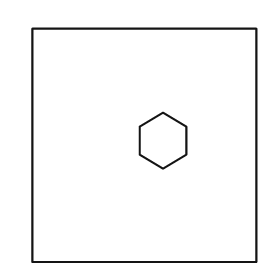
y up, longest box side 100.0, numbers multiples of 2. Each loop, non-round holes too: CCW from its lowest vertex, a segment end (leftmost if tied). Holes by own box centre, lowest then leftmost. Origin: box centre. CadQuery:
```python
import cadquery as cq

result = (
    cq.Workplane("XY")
    .moveTo(-48.0, -50.0)
    .lineTo(48.0, -50.0)
    .lineTo(48.0, 50.0)
    .lineTo(-48.0, 50.0)
    .close()
    .moveTo(8.0, -10.0)
    .lineTo(18.0, -4.0)
    .lineTo(18.0, 8.0)
    .lineTo(8.0, 14.0)
    .lineTo(-2.0, 8.0)
    .lineTo(-2.0, -4.0)
    .close()
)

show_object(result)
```